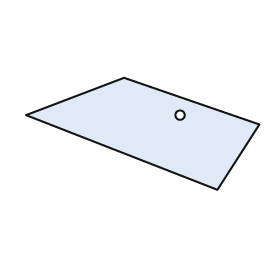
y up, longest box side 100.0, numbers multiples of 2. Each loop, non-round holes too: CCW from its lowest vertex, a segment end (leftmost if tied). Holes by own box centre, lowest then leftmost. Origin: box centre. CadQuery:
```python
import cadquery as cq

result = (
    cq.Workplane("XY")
    .moveTo(32.0, -24.0)
    .lineTo(50.0, 4.0)
    .lineTo(-8.0, 24.0)
    .lineTo(-50.0, 8.0)
    .close()
    .moveTo(16.0, 8.0)
    .circle(2.0)
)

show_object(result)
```